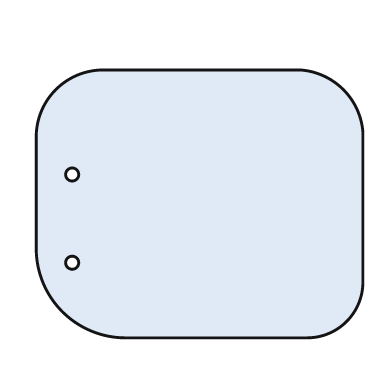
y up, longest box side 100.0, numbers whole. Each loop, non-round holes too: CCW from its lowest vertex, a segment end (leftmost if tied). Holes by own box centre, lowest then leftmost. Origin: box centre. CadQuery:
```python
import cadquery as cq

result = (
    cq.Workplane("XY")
    .moveTo(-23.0, -41.0)
    .lineTo(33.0, -41.0)
    .threePointArc((45.0, -36.0), (50.0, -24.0))
    .lineTo(50.0, 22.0)
    .threePointArc((44.0, 35.0), (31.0, 41.0))
    .lineTo(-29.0, 41.0)
    .threePointArc((-44.0, 35.0), (-50.0, 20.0))
    .lineTo(-50.0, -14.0)
    .threePointArc((-42.0, -33.0), (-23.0, -41.0))
    .close()
    .moveTo(-39.0, -18.0)
    .circle(2.0)
    .moveTo(-39.0, 9.0)
    .circle(2.0)
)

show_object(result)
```